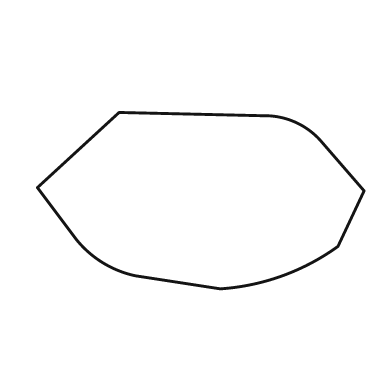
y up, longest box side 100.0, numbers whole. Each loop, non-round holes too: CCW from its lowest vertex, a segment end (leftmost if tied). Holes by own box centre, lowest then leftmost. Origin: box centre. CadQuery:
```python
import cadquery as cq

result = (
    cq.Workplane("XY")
    .moveTo(6.0, -27.0)
    .threePointArc((25.0, -23.0), (42.0, -14.0))
    .lineTo(50.0, 3.0)
    .lineTo(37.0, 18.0)
    .threePointArc((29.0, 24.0), (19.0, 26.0))
    .lineTo(-25.0, 27.0)
    .lineTo(-50.0, 4.0)
    .lineTo(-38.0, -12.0)
    .threePointArc((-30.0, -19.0), (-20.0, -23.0))
    .close()
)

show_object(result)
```